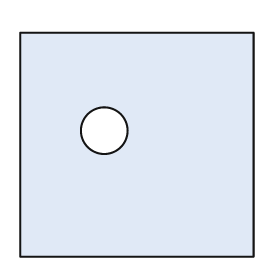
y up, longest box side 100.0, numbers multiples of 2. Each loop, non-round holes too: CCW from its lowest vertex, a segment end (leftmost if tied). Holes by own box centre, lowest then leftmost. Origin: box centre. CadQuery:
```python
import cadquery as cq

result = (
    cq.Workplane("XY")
    .moveTo(-50.0, -48.0)
    .lineTo(50.0, -48.0)
    .lineTo(50.0, 48.0)
    .lineTo(-50.0, 48.0)
    .close()
    .moveTo(-14.0, 6.0)
    .circle(10.0)
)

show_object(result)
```